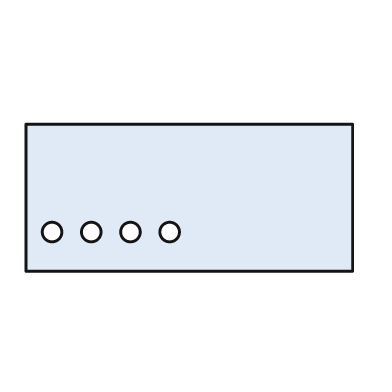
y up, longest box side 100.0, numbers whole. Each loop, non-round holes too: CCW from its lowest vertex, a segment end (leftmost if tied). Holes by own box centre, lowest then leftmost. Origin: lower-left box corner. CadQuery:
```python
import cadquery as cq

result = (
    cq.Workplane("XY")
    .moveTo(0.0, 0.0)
    .lineTo(100.0, 0.0)
    .lineTo(100.0, 45.0)
    .lineTo(0.0, 45.0)
    .close()
    .moveTo(8.0, 12.0)
    .circle(3.0)
    .moveTo(20.0, 12.0)
    .circle(3.0)
    .moveTo(32.0, 12.0)
    .circle(3.0)
    .moveTo(44.0, 12.0)
    .circle(3.0)
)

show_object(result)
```